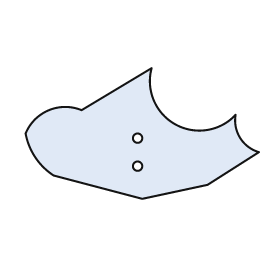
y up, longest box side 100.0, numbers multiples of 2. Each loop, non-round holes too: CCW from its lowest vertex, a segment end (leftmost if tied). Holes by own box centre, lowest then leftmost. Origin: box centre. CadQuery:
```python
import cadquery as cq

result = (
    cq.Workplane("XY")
    .moveTo(0.0, -28.0)
    .lineTo(28.0, -22.0)
    .lineTo(50.0, -8.0)
    .threePointArc((42.0, -2.0), (40.0, 8.0))
    .threePointArc((14.0, 4.0), (4.0, 28.0))
    .lineTo(-26.0, 10.0)
    .threePointArc((-40.0, 10.0), (-50.0, 0.0))
    .threePointArc((-46.0, -10.0), (-38.0, -18.0))
    .close()
    .moveTo(-2.0, -14.0)
    .circle(2.0)
    .moveTo(-2.0, -2.0)
    .circle(2.0)
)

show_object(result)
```